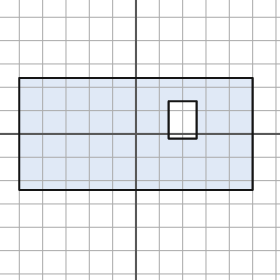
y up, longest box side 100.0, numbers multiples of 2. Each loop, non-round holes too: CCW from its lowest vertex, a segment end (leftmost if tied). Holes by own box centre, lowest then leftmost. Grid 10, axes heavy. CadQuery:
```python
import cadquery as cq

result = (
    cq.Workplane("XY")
    .moveTo(-50.0, -24.0)
    .lineTo(50.0, -24.0)
    .lineTo(50.0, 24.0)
    .lineTo(-50.0, 24.0)
    .close()
    .moveTo(14.0, -2.0)
    .lineTo(26.0, -2.0)
    .lineTo(26.0, 14.0)
    .lineTo(14.0, 14.0)
    .close()
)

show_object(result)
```